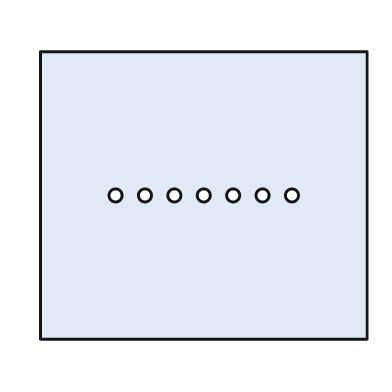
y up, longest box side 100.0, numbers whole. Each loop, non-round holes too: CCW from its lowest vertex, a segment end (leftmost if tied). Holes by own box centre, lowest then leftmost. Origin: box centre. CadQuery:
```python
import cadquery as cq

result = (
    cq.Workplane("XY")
    .moveTo(-50.0, -44.0)
    .lineTo(50.0, -44.0)
    .lineTo(50.0, 44.0)
    .lineTo(-50.0, 44.0)
    .close()
    .moveTo(-27.0, 0.0)
    .circle(2.0)
    .moveTo(-18.0, 0.0)
    .circle(2.0)
    .moveTo(-9.0, 0.0)
    .circle(2.0)
    .moveTo(0.0, 0.0)
    .circle(2.0)
    .moveTo(9.0, 0.0)
    .circle(2.0)
    .moveTo(18.0, 0.0)
    .circle(2.0)
    .moveTo(27.0, 0.0)
    .circle(2.0)
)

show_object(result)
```